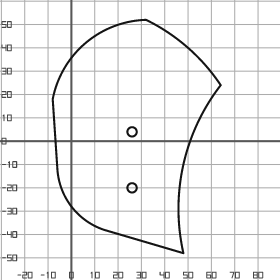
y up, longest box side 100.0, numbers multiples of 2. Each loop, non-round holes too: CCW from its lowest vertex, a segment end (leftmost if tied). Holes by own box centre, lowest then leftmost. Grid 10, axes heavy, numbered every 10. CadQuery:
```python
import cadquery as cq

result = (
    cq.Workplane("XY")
    .moveTo(48.0, -48.0)
    .threePointArc((48.0, -10.0), (64.0, 24.0))
    .threePointArc((50.0, 40.0), (32.0, 52.0))
    .threePointArc((6.0, 42.0), (-8.0, 18.0))
    .lineTo(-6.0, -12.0)
    .threePointArc((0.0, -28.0), (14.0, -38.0))
    .close()
    .moveTo(26.0, -20.0)
    .circle(2.0)
    .moveTo(26.0, 4.0)
    .circle(2.0)
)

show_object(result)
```